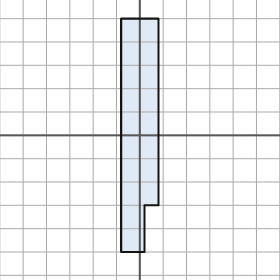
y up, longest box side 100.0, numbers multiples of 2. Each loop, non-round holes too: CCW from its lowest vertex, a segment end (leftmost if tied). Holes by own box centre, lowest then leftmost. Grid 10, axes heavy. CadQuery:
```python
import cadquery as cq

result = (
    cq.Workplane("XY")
    .moveTo(-8.0, -50.0)
    .lineTo(2.0, -50.0)
    .lineTo(2.0, -30.0)
    .lineTo(8.0, -30.0)
    .lineTo(8.0, 50.0)
    .lineTo(-8.0, 50.0)
    .close()
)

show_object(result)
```